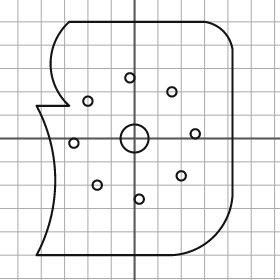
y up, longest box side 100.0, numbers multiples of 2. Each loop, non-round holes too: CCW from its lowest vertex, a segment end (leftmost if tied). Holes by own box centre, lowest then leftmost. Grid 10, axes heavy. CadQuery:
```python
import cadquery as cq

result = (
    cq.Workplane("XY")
    .moveTo(-42.0, -50.0)
    .lineTo(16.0, -50.0)
    .threePointArc((34.0, -42.0), (42.0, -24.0))
    .lineTo(42.0, 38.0)
    .threePointArc((38.0, 46.0), (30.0, 50.0))
    .lineTo(-28.0, 50.0)
    .threePointArc((-36.0, 32.0), (-28.0, 14.0))
    .lineTo(-42.0, 14.0)
    .threePointArc((-34.0, -18.0), (-42.0, -50.0))
    .close()
    .moveTo(2.0, -26.0)
    .circle(2.0)
    .moveTo(-16.0, -20.0)
    .circle(2.0)
    .moveTo(20.0, -16.0)
    .circle(2.0)
    .moveTo(-26.0, -2.0)
    .circle(2.0)
    .moveTo(0.0, 0.0)
    .circle(6.0)
    .moveTo(26.0, 2.0)
    .circle(2.0)
    .moveTo(-20.0, 16.0)
    .circle(2.0)
    .moveTo(16.0, 20.0)
    .circle(2.0)
    .moveTo(-2.0, 26.0)
    .circle(2.0)
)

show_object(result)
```